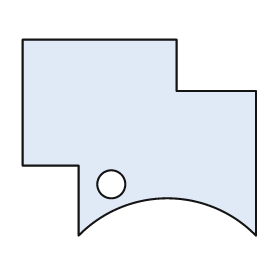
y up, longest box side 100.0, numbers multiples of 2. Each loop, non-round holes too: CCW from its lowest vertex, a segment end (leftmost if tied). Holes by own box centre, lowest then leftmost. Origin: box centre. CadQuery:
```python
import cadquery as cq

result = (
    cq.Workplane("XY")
    .moveTo(-26.0, -42.0)
    .threePointArc((12.0, -26.0), (50.0, -42.0))
    .lineTo(50.0, 20.0)
    .lineTo(16.0, 20.0)
    .lineTo(16.0, 42.0)
    .lineTo(-50.0, 42.0)
    .lineTo(-50.0, -12.0)
    .lineTo(-26.0, -12.0)
    .close()
    .moveTo(-12.0, -20.0)
    .circle(6.0)
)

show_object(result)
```